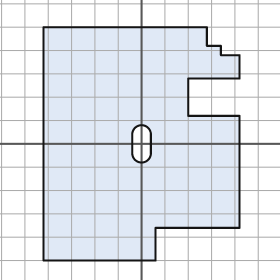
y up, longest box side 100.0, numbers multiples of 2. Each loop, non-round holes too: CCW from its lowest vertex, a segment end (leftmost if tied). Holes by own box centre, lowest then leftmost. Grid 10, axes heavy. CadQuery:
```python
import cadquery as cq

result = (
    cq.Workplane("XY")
    .moveTo(-42.0, -50.0)
    .lineTo(6.0, -50.0)
    .lineTo(6.0, -36.0)
    .lineTo(42.0, -36.0)
    .lineTo(42.0, 12.0)
    .lineTo(20.0, 12.0)
    .lineTo(20.0, 28.0)
    .lineTo(42.0, 28.0)
    .lineTo(42.0, 38.0)
    .lineTo(34.0, 38.0)
    .lineTo(34.0, 42.0)
    .lineTo(28.0, 42.0)
    .lineTo(28.0, 50.0)
    .lineTo(-42.0, 50.0)
    .close()
    .moveTo(-4.0, -4.0)
    .threePointArc((0.0, -8.0), (4.0, -4.0))
    .lineTo(4.0, 4.0)
    .threePointArc((0.0, 8.0), (-4.0, 4.0))
    .close()
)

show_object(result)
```